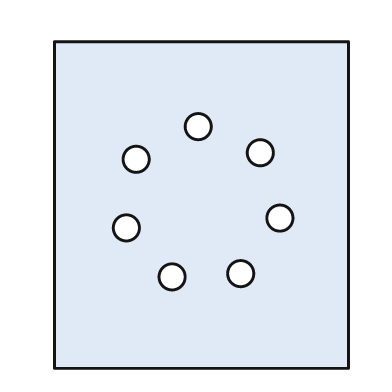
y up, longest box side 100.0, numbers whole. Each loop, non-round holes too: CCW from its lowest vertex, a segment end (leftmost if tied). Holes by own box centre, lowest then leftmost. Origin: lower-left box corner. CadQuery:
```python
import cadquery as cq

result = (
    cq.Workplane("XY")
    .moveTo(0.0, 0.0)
    .lineTo(90.0, 0.0)
    .lineTo(90.0, 100.0)
    .lineTo(0.0, 100.0)
    .close()
    .moveTo(36.0, 28.0)
    .circle(4.0)
    .moveTo(57.0, 29.0)
    .circle(4.0)
    .moveTo(22.0, 43.0)
    .circle(4.0)
    .moveTo(69.0, 46.0)
    .circle(4.0)
    .moveTo(25.0, 64.0)
    .circle(4.0)
    .moveTo(63.0, 66.0)
    .circle(4.0)
    .moveTo(44.0, 74.0)
    .circle(4.0)
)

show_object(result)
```